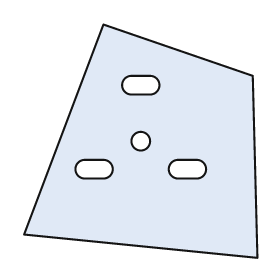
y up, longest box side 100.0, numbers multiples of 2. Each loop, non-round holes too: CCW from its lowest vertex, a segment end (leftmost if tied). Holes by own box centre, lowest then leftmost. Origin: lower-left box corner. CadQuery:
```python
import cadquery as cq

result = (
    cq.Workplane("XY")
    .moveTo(100.0, 0.0)
    .lineTo(98.0, 78.0)
    .lineTo(34.0, 100.0)
    .lineTo(0.0, 10.0)
    .close()
    .moveTo(26.0, 34.0)
    .lineTo(34.0, 34.0)
    .threePointArc((38.0, 38.0), (34.0, 42.0))
    .lineTo(26.0, 42.0)
    .threePointArc((22.0, 38.0), (26.0, 34.0))
    .close()
    .moveTo(66.0, 34.0)
    .lineTo(74.0, 34.0)
    .threePointArc((78.0, 38.0), (74.0, 42.0))
    .lineTo(66.0, 42.0)
    .threePointArc((62.0, 38.0), (66.0, 34.0))
    .close()
    .moveTo(50.0, 50.0)
    .circle(4.0)
    .moveTo(46.0, 70.0)
    .lineTo(54.0, 70.0)
    .threePointArc((58.0, 74.0), (54.0, 78.0))
    .lineTo(46.0, 78.0)
    .threePointArc((42.0, 74.0), (46.0, 70.0))
    .close()
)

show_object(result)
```